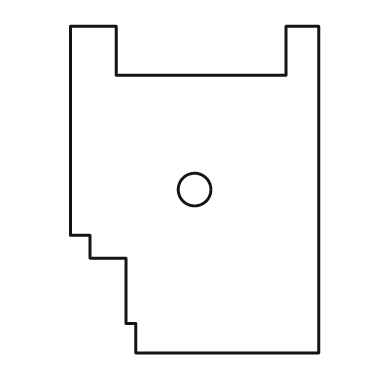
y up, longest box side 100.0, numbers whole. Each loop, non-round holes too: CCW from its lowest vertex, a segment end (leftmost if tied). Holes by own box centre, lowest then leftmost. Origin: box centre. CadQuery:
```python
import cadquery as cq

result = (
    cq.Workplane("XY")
    .moveTo(-18.0, -50.0)
    .lineTo(38.0, -50.0)
    .lineTo(38.0, 50.0)
    .lineTo(28.0, 50.0)
    .lineTo(28.0, 35.0)
    .lineTo(-24.0, 35.0)
    .lineTo(-24.0, 50.0)
    .lineTo(-38.0, 50.0)
    .lineTo(-38.0, -14.0)
    .lineTo(-32.0, -14.0)
    .lineTo(-32.0, -21.0)
    .lineTo(-21.0, -21.0)
    .lineTo(-21.0, -41.0)
    .lineTo(-18.0, -41.0)
    .close()
    .moveTo(0.0, 0.0)
    .circle(5.0)
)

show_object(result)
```